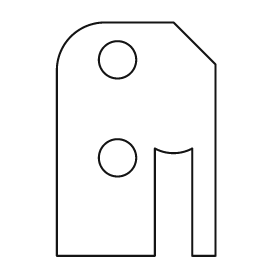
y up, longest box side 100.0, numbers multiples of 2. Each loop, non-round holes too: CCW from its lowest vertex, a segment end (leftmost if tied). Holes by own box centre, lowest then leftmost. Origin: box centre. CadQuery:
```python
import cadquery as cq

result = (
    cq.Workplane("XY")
    .moveTo(-34.0, -50.0)
    .lineTo(8.0, -50.0)
    .lineTo(8.0, -4.0)
    .threePointArc((16.0, -6.0), (24.0, -4.0))
    .lineTo(24.0, -50.0)
    .lineTo(34.0, -50.0)
    .lineTo(34.0, 32.0)
    .lineTo(16.0, 50.0)
    .lineTo(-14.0, 50.0)
    .threePointArc((-28.0, 44.0), (-34.0, 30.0))
    .close()
    .moveTo(-8.0, -8.0)
    .circle(8.0)
    .moveTo(-8.0, 34.0)
    .circle(8.0)
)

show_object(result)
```